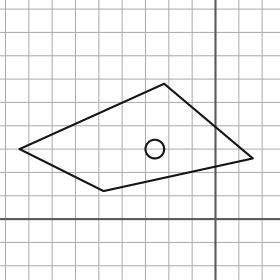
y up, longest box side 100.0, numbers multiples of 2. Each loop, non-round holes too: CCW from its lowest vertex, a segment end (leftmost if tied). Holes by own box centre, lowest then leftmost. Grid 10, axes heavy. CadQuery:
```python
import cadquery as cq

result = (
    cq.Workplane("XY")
    .moveTo(-48.0, 12.0)
    .lineTo(16.0, 26.0)
    .lineTo(-22.0, 58.0)
    .lineTo(-84.0, 30.0)
    .close()
    .moveTo(-26.0, 30.0)
    .circle(4.0)
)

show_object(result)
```